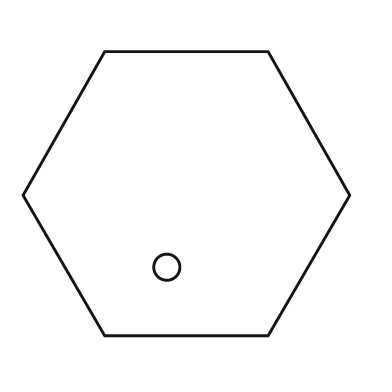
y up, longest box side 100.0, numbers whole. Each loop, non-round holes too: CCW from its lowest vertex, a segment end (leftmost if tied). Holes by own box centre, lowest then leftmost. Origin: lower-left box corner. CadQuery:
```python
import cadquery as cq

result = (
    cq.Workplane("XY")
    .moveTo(25.0, 0.0)
    .lineTo(75.0, 0.0)
    .lineTo(100.0, 43.0)
    .lineTo(75.0, 87.0)
    .lineTo(25.0, 87.0)
    .lineTo(0.0, 43.0)
    .close()
    .moveTo(44.0, 21.0)
    .circle(4.0)
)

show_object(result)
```